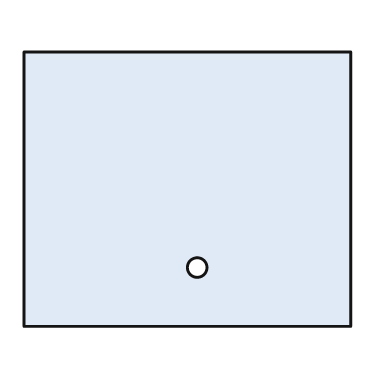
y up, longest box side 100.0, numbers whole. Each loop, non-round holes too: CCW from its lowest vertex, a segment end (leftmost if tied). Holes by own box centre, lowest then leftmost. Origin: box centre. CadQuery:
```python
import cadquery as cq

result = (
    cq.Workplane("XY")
    .moveTo(-50.0, -42.0)
    .lineTo(50.0, -42.0)
    .lineTo(50.0, 42.0)
    .lineTo(-50.0, 42.0)
    .close()
    .moveTo(3.0, -24.0)
    .circle(3.0)
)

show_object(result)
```